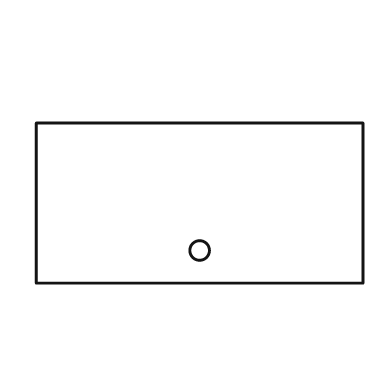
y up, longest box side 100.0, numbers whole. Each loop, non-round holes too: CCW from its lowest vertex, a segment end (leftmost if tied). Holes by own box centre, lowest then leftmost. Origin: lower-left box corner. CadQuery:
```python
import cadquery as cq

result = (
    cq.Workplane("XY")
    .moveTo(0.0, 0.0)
    .lineTo(100.0, 0.0)
    .lineTo(100.0, 49.0)
    .lineTo(0.0, 49.0)
    .close()
    .moveTo(50.0, 10.0)
    .circle(3.0)
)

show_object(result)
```